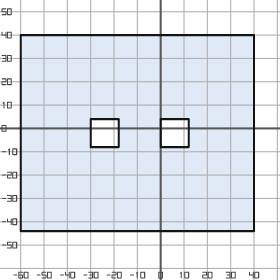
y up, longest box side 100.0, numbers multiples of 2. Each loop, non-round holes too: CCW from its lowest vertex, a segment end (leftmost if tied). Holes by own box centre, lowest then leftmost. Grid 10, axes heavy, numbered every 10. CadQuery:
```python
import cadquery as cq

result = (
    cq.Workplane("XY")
    .moveTo(-60.0, -44.0)
    .lineTo(40.0, -44.0)
    .lineTo(40.0, 40.0)
    .lineTo(-60.0, 40.0)
    .close()
    .moveTo(-30.0, -8.0)
    .lineTo(-18.0, -8.0)
    .lineTo(-18.0, 4.0)
    .lineTo(-30.0, 4.0)
    .close()
    .moveTo(0.0, -8.0)
    .lineTo(12.0, -8.0)
    .lineTo(12.0, 4.0)
    .lineTo(0.0, 4.0)
    .close()
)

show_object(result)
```